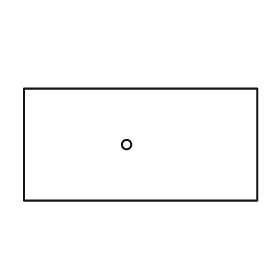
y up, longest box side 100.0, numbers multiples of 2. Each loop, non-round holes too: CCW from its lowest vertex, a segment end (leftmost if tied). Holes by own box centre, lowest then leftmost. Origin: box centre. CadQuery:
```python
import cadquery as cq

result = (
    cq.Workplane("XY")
    .moveTo(-50.0, -24.0)
    .lineTo(50.0, -24.0)
    .lineTo(50.0, 24.0)
    .lineTo(-50.0, 24.0)
    .close()
    .moveTo(-6.0, 0.0)
    .circle(2.0)
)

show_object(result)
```